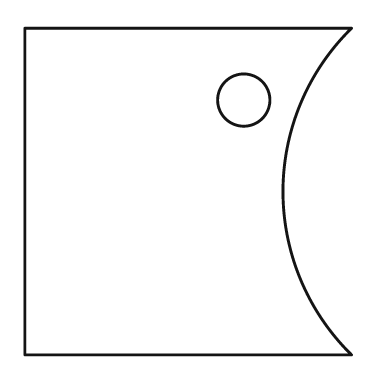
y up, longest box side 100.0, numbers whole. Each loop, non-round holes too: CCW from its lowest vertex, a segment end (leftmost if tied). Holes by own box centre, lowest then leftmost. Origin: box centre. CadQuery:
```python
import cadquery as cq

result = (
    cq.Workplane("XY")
    .moveTo(-50.0, -50.0)
    .lineTo(50.0, -50.0)
    .threePointArc((29.0, 0.0), (50.0, 50.0))
    .lineTo(-50.0, 50.0)
    .close()
    .moveTo(17.0, 28.0)
    .circle(8.0)
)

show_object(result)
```